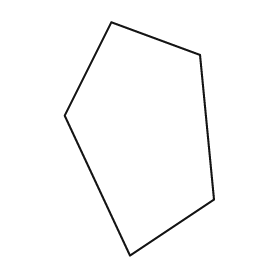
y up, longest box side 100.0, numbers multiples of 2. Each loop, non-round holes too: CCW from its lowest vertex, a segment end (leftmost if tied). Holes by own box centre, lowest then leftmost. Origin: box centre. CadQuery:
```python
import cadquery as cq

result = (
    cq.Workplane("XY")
    .moveTo(-4.0, -50.0)
    .lineTo(32.0, -26.0)
    .lineTo(26.0, 36.0)
    .lineTo(-12.0, 50.0)
    .lineTo(-32.0, 10.0)
    .close()
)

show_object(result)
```